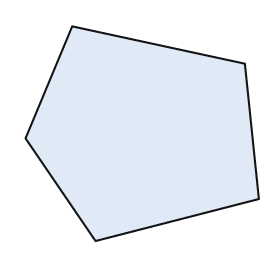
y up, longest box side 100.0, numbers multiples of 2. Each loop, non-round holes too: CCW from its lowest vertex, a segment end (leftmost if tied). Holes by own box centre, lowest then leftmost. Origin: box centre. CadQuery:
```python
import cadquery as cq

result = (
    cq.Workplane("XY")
    .moveTo(-20.0, -46.0)
    .lineTo(50.0, -28.0)
    .lineTo(44.0, 30.0)
    .lineTo(-30.0, 46.0)
    .lineTo(-50.0, -2.0)
    .close()
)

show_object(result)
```